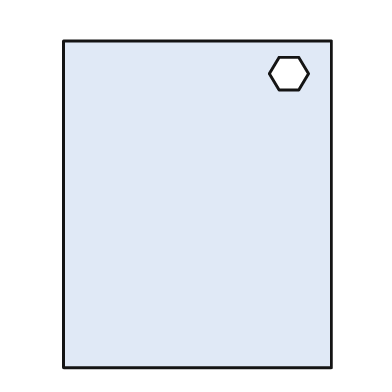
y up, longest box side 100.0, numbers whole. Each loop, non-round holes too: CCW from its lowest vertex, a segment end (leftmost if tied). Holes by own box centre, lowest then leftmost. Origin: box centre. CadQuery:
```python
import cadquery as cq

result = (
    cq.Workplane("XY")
    .moveTo(-41.0, -50.0)
    .lineTo(41.0, -50.0)
    .lineTo(41.0, 50.0)
    .lineTo(-41.0, 50.0)
    .close()
    .moveTo(25.0, 35.0)
    .lineTo(31.0, 35.0)
    .lineTo(34.0, 40.0)
    .lineTo(31.0, 45.0)
    .lineTo(25.0, 45.0)
    .lineTo(22.0, 40.0)
    .close()
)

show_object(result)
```